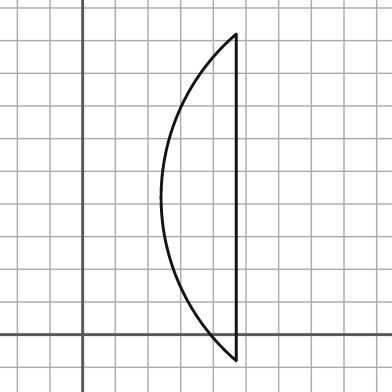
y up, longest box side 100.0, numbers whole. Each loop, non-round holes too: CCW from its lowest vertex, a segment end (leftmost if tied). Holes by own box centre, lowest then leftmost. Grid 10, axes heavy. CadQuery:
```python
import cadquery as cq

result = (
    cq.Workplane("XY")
    .moveTo(47.0, -8.0)
    .lineTo(47.0, 92.0)
    .threePointArc((24.0, 42.0), (47.0, -8.0))
    .close()
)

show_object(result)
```